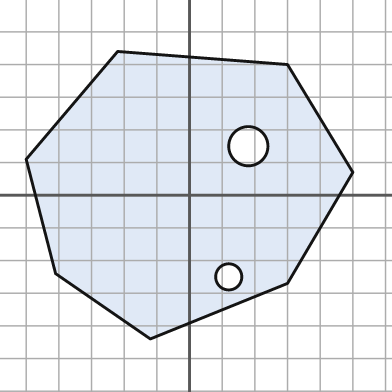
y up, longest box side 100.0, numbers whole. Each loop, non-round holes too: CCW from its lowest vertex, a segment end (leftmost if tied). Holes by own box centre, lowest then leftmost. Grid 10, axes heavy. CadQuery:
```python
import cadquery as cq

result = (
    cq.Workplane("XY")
    .moveTo(-12.0, -44.0)
    .lineTo(30.0, -27.0)
    .lineTo(50.0, 7.0)
    .lineTo(30.0, 40.0)
    .lineTo(-22.0, 44.0)
    .lineTo(-50.0, 11.0)
    .lineTo(-41.0, -24.0)
    .close()
    .moveTo(12.0, -25.0)
    .circle(4.0)
    .moveTo(18.0, 15.0)
    .circle(6.0)
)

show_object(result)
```